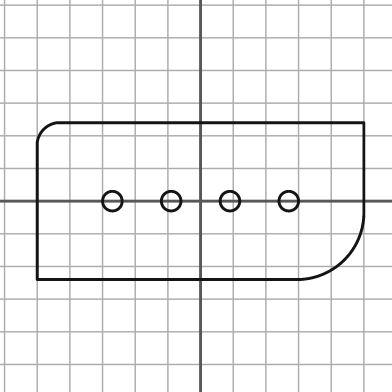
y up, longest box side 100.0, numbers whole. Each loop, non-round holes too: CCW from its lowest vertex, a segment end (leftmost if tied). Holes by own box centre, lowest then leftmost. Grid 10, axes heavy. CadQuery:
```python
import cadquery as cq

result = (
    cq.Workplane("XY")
    .moveTo(-50.0, -24.0)
    .lineTo(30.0, -24.0)
    .threePointArc((44.0, -18.0), (50.0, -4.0))
    .lineTo(50.0, 24.0)
    .lineTo(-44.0, 24.0)
    .threePointArc((-48.0, 22.0), (-50.0, 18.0))
    .close()
    .moveTo(-27.0, 0.0)
    .circle(3.0)
    .moveTo(-9.0, 0.0)
    .circle(3.0)
    .moveTo(9.0, 0.0)
    .circle(3.0)
    .moveTo(27.0, 0.0)
    .circle(3.0)
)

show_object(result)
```